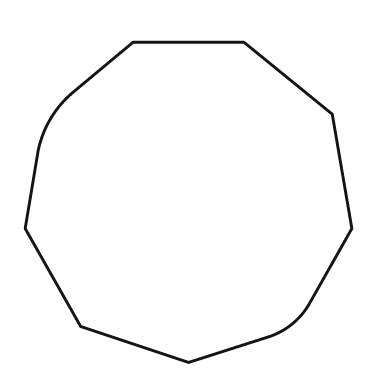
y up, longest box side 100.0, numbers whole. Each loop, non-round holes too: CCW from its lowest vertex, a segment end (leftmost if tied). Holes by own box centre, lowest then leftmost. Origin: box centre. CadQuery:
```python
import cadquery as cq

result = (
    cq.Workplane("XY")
    .moveTo(0.0, -49.0)
    .lineTo(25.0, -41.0)
    .threePointArc((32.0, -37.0), (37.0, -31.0))
    .lineTo(50.0, -8.0)
    .lineTo(44.0, 27.0)
    .lineTo(17.0, 49.0)
    .lineTo(-17.0, 49.0)
    .lineTo(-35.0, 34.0)
    .threePointArc((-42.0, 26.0), (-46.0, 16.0))
    .lineTo(-50.0, -8.0)
    .lineTo(-33.0, -38.0)
    .close()
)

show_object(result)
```